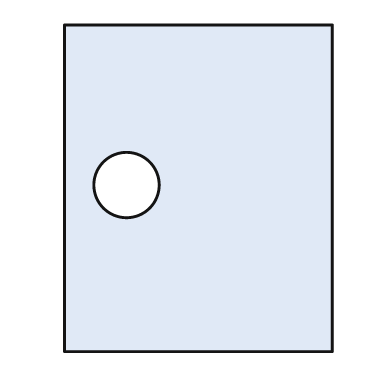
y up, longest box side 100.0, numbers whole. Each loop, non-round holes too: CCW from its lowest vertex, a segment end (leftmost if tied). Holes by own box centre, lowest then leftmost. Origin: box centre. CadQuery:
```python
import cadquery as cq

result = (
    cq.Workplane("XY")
    .moveTo(-41.0, -50.0)
    .lineTo(41.0, -50.0)
    .lineTo(41.0, 50.0)
    .lineTo(-41.0, 50.0)
    .close()
    .moveTo(-22.0, 1.0)
    .circle(10.0)
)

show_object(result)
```